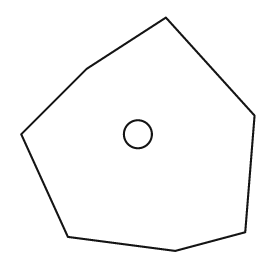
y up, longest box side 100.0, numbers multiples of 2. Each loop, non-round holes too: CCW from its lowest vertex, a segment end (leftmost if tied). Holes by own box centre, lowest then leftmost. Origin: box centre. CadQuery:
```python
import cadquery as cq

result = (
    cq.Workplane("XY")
    .moveTo(16.0, -50.0)
    .lineTo(46.0, -42.0)
    .lineTo(50.0, 8.0)
    .lineTo(12.0, 50.0)
    .lineTo(-22.0, 28.0)
    .lineTo(-50.0, 0.0)
    .lineTo(-30.0, -44.0)
    .close()
    .moveTo(0.0, 0.0)
    .circle(6.0)
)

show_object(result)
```